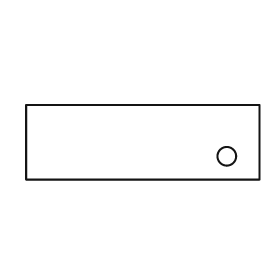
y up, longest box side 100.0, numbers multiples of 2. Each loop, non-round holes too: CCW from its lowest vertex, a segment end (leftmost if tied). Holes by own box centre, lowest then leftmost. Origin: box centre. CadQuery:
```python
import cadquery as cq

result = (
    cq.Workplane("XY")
    .moveTo(-50.0, -16.0)
    .lineTo(50.0, -16.0)
    .lineTo(50.0, 16.0)
    .lineTo(-50.0, 16.0)
    .close()
    .moveTo(36.0, -6.0)
    .circle(4.0)
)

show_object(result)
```